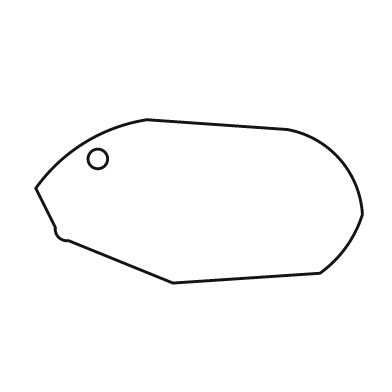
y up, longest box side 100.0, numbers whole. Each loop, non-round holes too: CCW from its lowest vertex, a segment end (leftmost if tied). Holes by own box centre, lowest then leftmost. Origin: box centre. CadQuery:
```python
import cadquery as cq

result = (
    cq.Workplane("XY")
    .moveTo(-8.0, -25.0)
    .lineTo(37.0, -22.0)
    .threePointArc((45.0, -14.0), (50.0, -4.0))
    .threePointArc((43.0, 13.0), (27.0, 22.0))
    .lineTo(-16.0, 25.0)
    .threePointArc((-35.0, 18.0), (-50.0, 4.0))
    .lineTo(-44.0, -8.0)
    .threePointArc((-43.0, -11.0), (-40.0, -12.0))
    .close()
    .moveTo(-31.0, 13.0)
    .circle(3.0)
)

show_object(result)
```